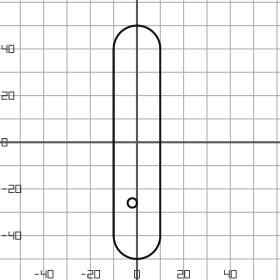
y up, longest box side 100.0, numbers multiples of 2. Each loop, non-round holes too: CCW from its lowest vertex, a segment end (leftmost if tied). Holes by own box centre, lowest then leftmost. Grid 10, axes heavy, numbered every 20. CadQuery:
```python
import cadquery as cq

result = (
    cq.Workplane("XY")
    .moveTo(-10.0, -40.0)
    .threePointArc((0.0, -50.0), (10.0, -40.0))
    .lineTo(10.0, 40.0)
    .threePointArc((0.0, 50.0), (-10.0, 40.0))
    .close()
    .moveTo(-2.0, -26.0)
    .circle(2.0)
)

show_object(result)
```